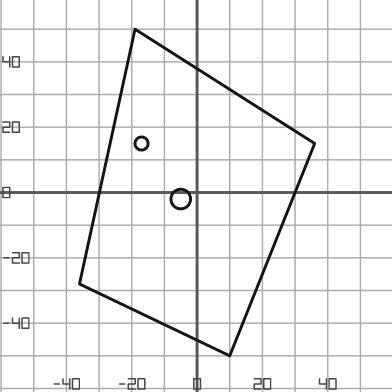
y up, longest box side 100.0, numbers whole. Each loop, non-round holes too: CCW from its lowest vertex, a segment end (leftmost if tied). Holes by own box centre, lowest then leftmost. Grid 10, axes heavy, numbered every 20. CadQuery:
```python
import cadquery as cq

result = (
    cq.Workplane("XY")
    .moveTo(10.0, -50.0)
    .lineTo(36.0, 15.0)
    .lineTo(-19.0, 50.0)
    .lineTo(-36.0, -28.0)
    .close()
    .moveTo(-5.0, -2.0)
    .circle(3.0)
    .moveTo(-17.0, 15.0)
    .circle(2.0)
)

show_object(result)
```